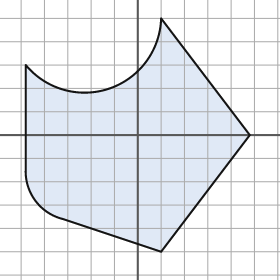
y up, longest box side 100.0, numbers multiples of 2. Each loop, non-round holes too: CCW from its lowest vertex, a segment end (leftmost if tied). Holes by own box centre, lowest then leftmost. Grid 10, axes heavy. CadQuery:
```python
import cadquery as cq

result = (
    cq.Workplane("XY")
    .moveTo(10.0, -50.0)
    .lineTo(48.0, 0.0)
    .lineTo(10.0, 50.0)
    .threePointArc((-12.0, 20.0), (-48.0, 30.0))
    .lineTo(-48.0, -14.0)
    .threePointArc((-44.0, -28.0), (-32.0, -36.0))
    .close()
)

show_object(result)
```